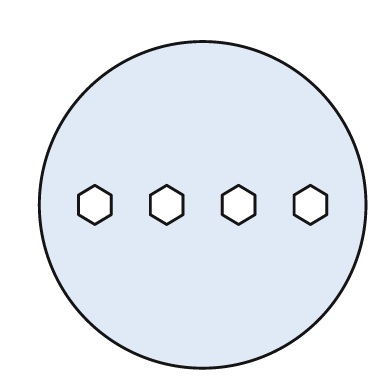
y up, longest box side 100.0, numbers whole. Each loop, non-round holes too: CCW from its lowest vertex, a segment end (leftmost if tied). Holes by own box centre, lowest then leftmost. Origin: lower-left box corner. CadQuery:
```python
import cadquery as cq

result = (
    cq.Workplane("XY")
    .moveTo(50.0, 50.0)
    .circle(50.0)
    .moveTo(17.0, 44.0)
    .lineTo(22.0, 47.0)
    .lineTo(22.0, 53.0)
    .lineTo(17.0, 56.0)
    .lineTo(12.0, 53.0)
    .lineTo(12.0, 47.0)
    .close()
    .moveTo(39.0, 44.0)
    .lineTo(44.0, 47.0)
    .lineTo(44.0, 53.0)
    .lineTo(39.0, 56.0)
    .lineTo(34.0, 53.0)
    .lineTo(34.0, 47.0)
    .close()
    .moveTo(61.0, 44.0)
    .lineTo(66.0, 47.0)
    .lineTo(66.0, 53.0)
    .lineTo(61.0, 56.0)
    .lineTo(56.0, 53.0)
    .lineTo(56.0, 47.0)
    .close()
    .moveTo(83.0, 44.0)
    .lineTo(88.0, 47.0)
    .lineTo(88.0, 53.0)
    .lineTo(83.0, 56.0)
    .lineTo(78.0, 53.0)
    .lineTo(78.0, 47.0)
    .close()
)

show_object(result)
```